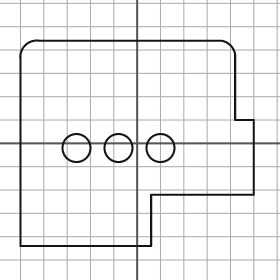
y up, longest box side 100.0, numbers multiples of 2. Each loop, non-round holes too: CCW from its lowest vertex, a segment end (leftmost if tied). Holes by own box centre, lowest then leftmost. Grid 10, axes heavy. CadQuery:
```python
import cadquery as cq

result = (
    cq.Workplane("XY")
    .moveTo(-50.0, -44.0)
    .lineTo(6.0, -44.0)
    .lineTo(6.0, -22.0)
    .lineTo(50.0, -22.0)
    .lineTo(50.0, 10.0)
    .lineTo(42.0, 10.0)
    .lineTo(42.0, 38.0)
    .threePointArc((40.0, 42.0), (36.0, 44.0))
    .lineTo(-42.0, 44.0)
    .threePointArc((-48.0, 42.0), (-50.0, 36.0))
    .close()
    .moveTo(-26.0, -2.0)
    .circle(6.0)
    .moveTo(-8.0, -2.0)
    .circle(6.0)
    .moveTo(10.0, -2.0)
    .circle(6.0)
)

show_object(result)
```